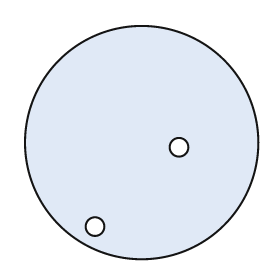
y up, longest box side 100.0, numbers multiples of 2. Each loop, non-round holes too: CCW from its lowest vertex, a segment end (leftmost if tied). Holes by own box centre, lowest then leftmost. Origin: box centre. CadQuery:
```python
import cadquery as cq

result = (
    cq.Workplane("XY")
    .moveTo(0.0, 0.0)
    .circle(50.0)
    .moveTo(-20.0, -36.0)
    .circle(4.0)
    .moveTo(16.0, -2.0)
    .circle(4.0)
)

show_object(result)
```